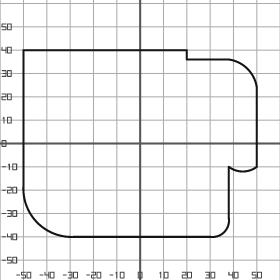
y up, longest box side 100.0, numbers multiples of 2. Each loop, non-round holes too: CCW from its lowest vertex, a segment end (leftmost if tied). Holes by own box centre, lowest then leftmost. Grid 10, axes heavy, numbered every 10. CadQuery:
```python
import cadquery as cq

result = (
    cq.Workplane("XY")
    .moveTo(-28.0, -40.0)
    .lineTo(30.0, -40.0)
    .threePointArc((36.0, -38.0), (38.0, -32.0))
    .lineTo(38.0, -10.0)
    .threePointArc((44.0, -12.0), (50.0, -10.0))
    .lineTo(50.0, 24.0)
    .threePointArc((46.0, 32.0), (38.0, 36.0))
    .lineTo(20.0, 36.0)
    .lineTo(20.0, 40.0)
    .lineTo(-50.0, 40.0)
    .lineTo(-50.0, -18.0)
    .threePointArc((-44.0, -34.0), (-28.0, -40.0))
    .close()
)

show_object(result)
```